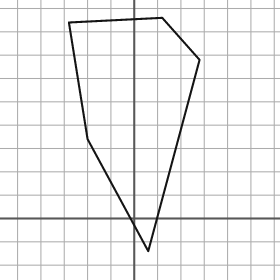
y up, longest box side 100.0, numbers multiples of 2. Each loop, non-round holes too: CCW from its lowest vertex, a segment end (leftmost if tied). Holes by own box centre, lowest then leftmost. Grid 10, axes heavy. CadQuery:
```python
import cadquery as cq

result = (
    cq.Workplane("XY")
    .moveTo(6.0, -14.0)
    .lineTo(28.0, 68.0)
    .lineTo(12.0, 86.0)
    .lineTo(-28.0, 84.0)
    .lineTo(-20.0, 34.0)
    .close()
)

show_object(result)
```